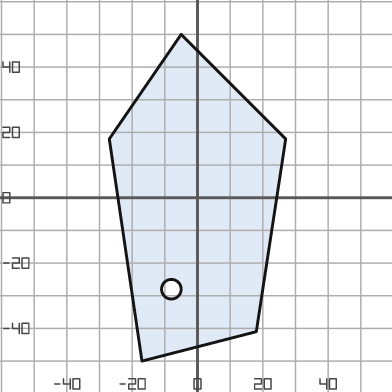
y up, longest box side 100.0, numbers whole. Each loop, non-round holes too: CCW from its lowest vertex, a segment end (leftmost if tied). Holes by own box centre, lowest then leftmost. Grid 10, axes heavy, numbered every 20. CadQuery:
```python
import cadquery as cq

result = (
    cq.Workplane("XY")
    .moveTo(-17.0, -50.0)
    .lineTo(18.0, -41.0)
    .lineTo(27.0, 18.0)
    .lineTo(-5.0, 50.0)
    .lineTo(-27.0, 18.0)
    .close()
    .moveTo(-8.0, -28.0)
    .circle(3.0)
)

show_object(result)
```